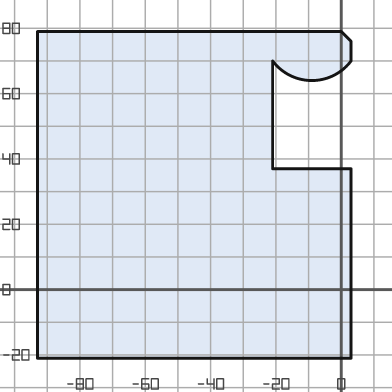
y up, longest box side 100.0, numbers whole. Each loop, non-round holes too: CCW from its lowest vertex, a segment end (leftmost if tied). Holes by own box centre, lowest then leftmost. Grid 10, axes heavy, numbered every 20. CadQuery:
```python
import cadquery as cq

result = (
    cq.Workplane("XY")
    .moveTo(-93.0, -21.0)
    .lineTo(3.0, -21.0)
    .lineTo(3.0, 37.0)
    .lineTo(-21.0, 37.0)
    .lineTo(-21.0, 70.0)
    .threePointArc((-9.0, 64.0), (3.0, 70.0))
    .lineTo(3.0, 76.0)
    .lineTo(0.0, 79.0)
    .lineTo(-93.0, 79.0)
    .close()
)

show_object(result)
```